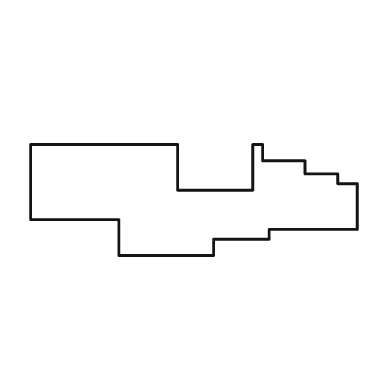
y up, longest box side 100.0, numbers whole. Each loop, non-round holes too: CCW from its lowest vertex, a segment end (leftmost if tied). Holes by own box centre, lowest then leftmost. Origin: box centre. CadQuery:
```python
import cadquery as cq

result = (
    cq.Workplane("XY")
    .moveTo(-23.0, -17.0)
    .lineTo(6.0, -17.0)
    .lineTo(6.0, -12.0)
    .lineTo(23.0, -12.0)
    .lineTo(23.0, -9.0)
    .lineTo(50.0, -9.0)
    .lineTo(50.0, 5.0)
    .lineTo(44.0, 5.0)
    .lineTo(44.0, 8.0)
    .lineTo(34.0, 8.0)
    .lineTo(34.0, 12.0)
    .lineTo(21.0, 12.0)
    .lineTo(21.0, 17.0)
    .lineTo(18.0, 17.0)
    .lineTo(18.0, 3.0)
    .lineTo(-5.0, 3.0)
    .lineTo(-5.0, 17.0)
    .lineTo(-50.0, 17.0)
    .lineTo(-50.0, -6.0)
    .lineTo(-23.0, -6.0)
    .close()
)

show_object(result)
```